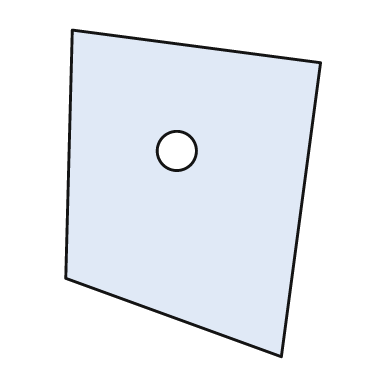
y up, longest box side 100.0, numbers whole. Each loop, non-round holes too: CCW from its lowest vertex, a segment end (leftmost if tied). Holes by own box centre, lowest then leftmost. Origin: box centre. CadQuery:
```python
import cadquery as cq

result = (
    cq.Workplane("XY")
    .moveTo(27.0, -50.0)
    .lineTo(39.0, 40.0)
    .lineTo(-37.0, 50.0)
    .lineTo(-39.0, -26.0)
    .close()
    .moveTo(-5.0, 13.0)
    .circle(6.0)
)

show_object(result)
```